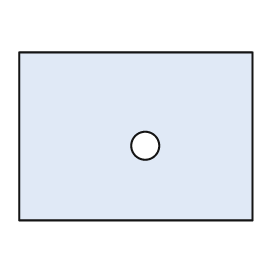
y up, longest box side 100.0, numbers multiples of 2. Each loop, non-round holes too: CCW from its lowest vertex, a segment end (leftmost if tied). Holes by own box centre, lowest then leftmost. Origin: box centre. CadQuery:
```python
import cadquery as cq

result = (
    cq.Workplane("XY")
    .moveTo(-50.0, -36.0)
    .lineTo(50.0, -36.0)
    .lineTo(50.0, 36.0)
    .lineTo(-50.0, 36.0)
    .close()
    .moveTo(4.0, -4.0)
    .circle(6.0)
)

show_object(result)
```